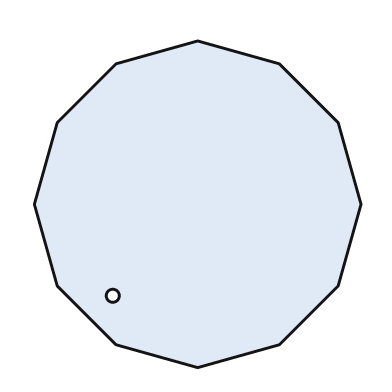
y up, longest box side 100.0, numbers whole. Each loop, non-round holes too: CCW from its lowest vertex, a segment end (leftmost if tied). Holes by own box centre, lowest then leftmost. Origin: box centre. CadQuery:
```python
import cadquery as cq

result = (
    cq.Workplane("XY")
    .moveTo(0.0, -50.0)
    .lineTo(25.0, -43.0)
    .lineTo(43.0, -25.0)
    .lineTo(50.0, 0.0)
    .lineTo(43.0, 25.0)
    .lineTo(25.0, 43.0)
    .lineTo(0.0, 50.0)
    .lineTo(-25.0, 43.0)
    .lineTo(-43.0, 25.0)
    .lineTo(-50.0, 0.0)
    .lineTo(-43.0, -25.0)
    .lineTo(-25.0, -43.0)
    .close()
    .moveTo(-26.0, -28.0)
    .circle(2.0)
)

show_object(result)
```